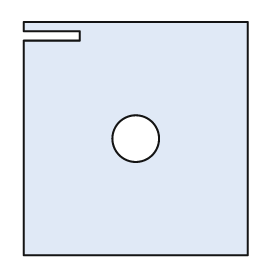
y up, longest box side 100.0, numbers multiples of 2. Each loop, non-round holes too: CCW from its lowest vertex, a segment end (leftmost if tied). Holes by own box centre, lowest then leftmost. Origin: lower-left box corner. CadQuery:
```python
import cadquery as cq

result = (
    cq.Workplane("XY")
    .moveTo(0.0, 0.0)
    .lineTo(96.0, 0.0)
    .lineTo(96.0, 100.0)
    .lineTo(0.0, 100.0)
    .lineTo(0.0, 96.0)
    .lineTo(24.0, 96.0)
    .lineTo(24.0, 92.0)
    .lineTo(0.0, 92.0)
    .close()
    .moveTo(48.0, 50.0)
    .circle(10.0)
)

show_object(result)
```